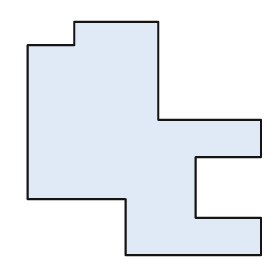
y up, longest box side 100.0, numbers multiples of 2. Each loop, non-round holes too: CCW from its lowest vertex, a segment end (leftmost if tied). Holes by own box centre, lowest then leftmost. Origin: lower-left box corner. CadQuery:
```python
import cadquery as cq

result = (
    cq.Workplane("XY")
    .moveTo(42.0, 0.0)
    .lineTo(100.0, 0.0)
    .lineTo(100.0, 16.0)
    .lineTo(72.0, 16.0)
    .lineTo(72.0, 42.0)
    .lineTo(100.0, 42.0)
    .lineTo(100.0, 58.0)
    .lineTo(56.0, 58.0)
    .lineTo(56.0, 100.0)
    .lineTo(20.0, 100.0)
    .lineTo(20.0, 90.0)
    .lineTo(0.0, 90.0)
    .lineTo(0.0, 24.0)
    .lineTo(42.0, 24.0)
    .close()
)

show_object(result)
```